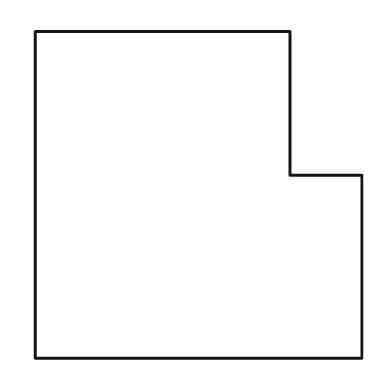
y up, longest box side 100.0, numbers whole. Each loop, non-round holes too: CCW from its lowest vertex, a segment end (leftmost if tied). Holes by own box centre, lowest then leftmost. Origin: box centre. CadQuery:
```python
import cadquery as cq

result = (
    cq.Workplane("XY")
    .moveTo(-50.0, -50.0)
    .lineTo(50.0, -50.0)
    .lineTo(50.0, 6.0)
    .lineTo(28.0, 6.0)
    .lineTo(28.0, 50.0)
    .lineTo(-50.0, 50.0)
    .close()
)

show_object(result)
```